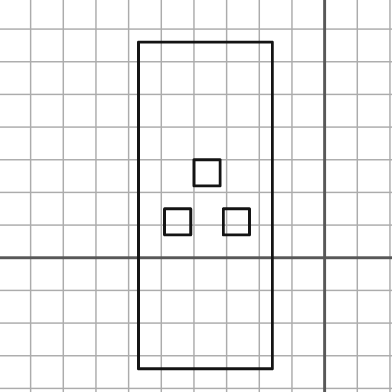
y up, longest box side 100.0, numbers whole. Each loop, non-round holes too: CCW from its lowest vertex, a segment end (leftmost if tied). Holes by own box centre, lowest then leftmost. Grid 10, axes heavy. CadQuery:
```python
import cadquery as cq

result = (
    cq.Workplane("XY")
    .moveTo(-57.0, -34.0)
    .lineTo(-16.0, -34.0)
    .lineTo(-16.0, 66.0)
    .lineTo(-57.0, 66.0)
    .close()
    .moveTo(-49.0, 7.0)
    .lineTo(-41.0, 7.0)
    .lineTo(-41.0, 15.0)
    .lineTo(-49.0, 15.0)
    .close()
    .moveTo(-31.0, 7.0)
    .lineTo(-23.0, 7.0)
    .lineTo(-23.0, 15.0)
    .lineTo(-31.0, 15.0)
    .close()
    .moveTo(-40.0, 22.0)
    .lineTo(-32.0, 22.0)
    .lineTo(-32.0, 30.0)
    .lineTo(-40.0, 30.0)
    .close()
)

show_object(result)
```